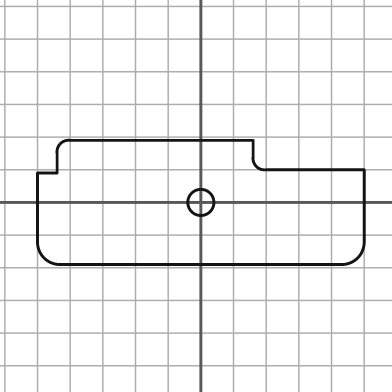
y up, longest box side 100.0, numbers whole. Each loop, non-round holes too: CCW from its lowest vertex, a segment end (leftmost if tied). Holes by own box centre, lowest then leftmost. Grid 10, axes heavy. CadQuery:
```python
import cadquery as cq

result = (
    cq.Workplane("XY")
    .moveTo(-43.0, -19.0)
    .lineTo(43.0, -19.0)
    .threePointArc((48.0, -17.0), (50.0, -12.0))
    .lineTo(50.0, 10.0)
    .lineTo(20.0, 10.0)
    .threePointArc((17.0, 11.0), (16.0, 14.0))
    .lineTo(16.0, 19.0)
    .lineTo(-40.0, 19.0)
    .threePointArc((-43.0, 18.0), (-44.0, 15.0))
    .lineTo(-44.0, 9.0)
    .lineTo(-50.0, 9.0)
    .lineTo(-50.0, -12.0)
    .threePointArc((-48.0, -17.0), (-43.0, -19.0))
    .close()
    .moveTo(0.0, 0.0)
    .circle(4.0)
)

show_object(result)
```